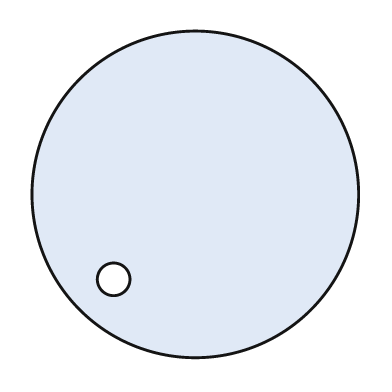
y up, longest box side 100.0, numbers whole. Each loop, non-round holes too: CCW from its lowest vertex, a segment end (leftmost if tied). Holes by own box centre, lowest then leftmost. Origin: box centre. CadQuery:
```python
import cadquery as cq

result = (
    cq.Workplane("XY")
    .moveTo(0.0, 0.0)
    .circle(50.0)
    .moveTo(-25.0, -26.0)
    .circle(5.0)
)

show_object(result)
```